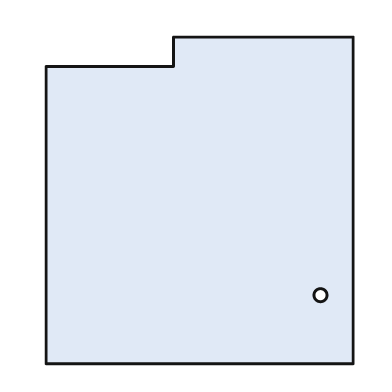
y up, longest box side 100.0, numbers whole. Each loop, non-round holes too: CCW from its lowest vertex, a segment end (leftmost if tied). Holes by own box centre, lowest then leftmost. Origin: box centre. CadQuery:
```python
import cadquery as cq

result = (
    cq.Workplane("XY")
    .moveTo(-47.0, -50.0)
    .lineTo(47.0, -50.0)
    .lineTo(47.0, 50.0)
    .lineTo(-8.0, 50.0)
    .lineTo(-8.0, 41.0)
    .lineTo(-47.0, 41.0)
    .close()
    .moveTo(37.0, -29.0)
    .circle(2.0)
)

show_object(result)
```